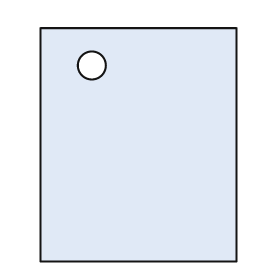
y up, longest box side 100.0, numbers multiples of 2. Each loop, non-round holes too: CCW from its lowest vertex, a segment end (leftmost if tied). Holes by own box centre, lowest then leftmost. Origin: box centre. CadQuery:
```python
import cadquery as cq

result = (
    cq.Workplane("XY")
    .moveTo(-42.0, -50.0)
    .lineTo(42.0, -50.0)
    .lineTo(42.0, 50.0)
    .lineTo(-42.0, 50.0)
    .close()
    .moveTo(-20.0, 34.0)
    .circle(6.0)
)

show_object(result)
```